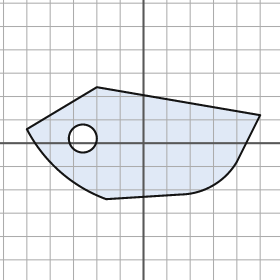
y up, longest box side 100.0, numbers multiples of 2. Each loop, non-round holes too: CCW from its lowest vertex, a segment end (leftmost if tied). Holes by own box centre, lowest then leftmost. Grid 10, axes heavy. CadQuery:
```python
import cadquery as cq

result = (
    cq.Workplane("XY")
    .moveTo(-16.0, -24.0)
    .lineTo(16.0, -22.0)
    .threePointArc((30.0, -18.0), (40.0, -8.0))
    .lineTo(50.0, 12.0)
    .lineTo(-20.0, 24.0)
    .lineTo(-50.0, 6.0)
    .threePointArc((-36.0, -12.0), (-16.0, -24.0))
    .close()
    .moveTo(-26.0, 2.0)
    .circle(6.0)
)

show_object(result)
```